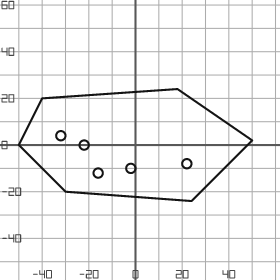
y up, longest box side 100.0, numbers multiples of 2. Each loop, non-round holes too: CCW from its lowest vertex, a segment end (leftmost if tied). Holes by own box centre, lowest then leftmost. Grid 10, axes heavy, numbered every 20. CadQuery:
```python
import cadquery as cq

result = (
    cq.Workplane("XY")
    .moveTo(24.0, -24.0)
    .lineTo(50.0, 2.0)
    .lineTo(18.0, 24.0)
    .lineTo(-40.0, 20.0)
    .lineTo(-50.0, 0.0)
    .lineTo(-30.0, -20.0)
    .close()
    .moveTo(-16.0, -12.0)
    .circle(2.0)
    .moveTo(-2.0, -10.0)
    .circle(2.0)
    .moveTo(22.0, -8.0)
    .circle(2.0)
    .moveTo(-22.0, 0.0)
    .circle(2.0)
    .moveTo(-32.0, 4.0)
    .circle(2.0)
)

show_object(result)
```